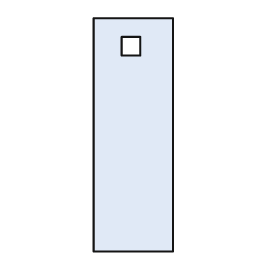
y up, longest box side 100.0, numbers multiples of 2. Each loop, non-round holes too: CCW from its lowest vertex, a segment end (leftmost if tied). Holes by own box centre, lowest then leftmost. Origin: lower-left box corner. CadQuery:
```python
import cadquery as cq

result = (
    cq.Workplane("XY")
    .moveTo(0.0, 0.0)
    .lineTo(34.0, 0.0)
    .lineTo(34.0, 100.0)
    .lineTo(0.0, 100.0)
    .close()
    .moveTo(12.0, 84.0)
    .lineTo(20.0, 84.0)
    .lineTo(20.0, 92.0)
    .lineTo(12.0, 92.0)
    .close()
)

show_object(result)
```